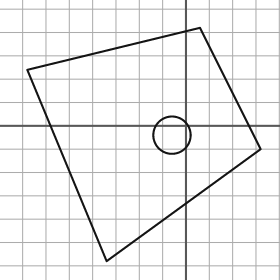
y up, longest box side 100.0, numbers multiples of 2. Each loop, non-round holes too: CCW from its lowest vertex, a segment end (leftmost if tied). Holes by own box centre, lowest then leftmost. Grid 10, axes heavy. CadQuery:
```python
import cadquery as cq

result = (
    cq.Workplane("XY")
    .moveTo(-34.0, -58.0)
    .lineTo(32.0, -10.0)
    .lineTo(6.0, 42.0)
    .lineTo(-68.0, 24.0)
    .close()
    .moveTo(-6.0, -4.0)
    .circle(8.0)
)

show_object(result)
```